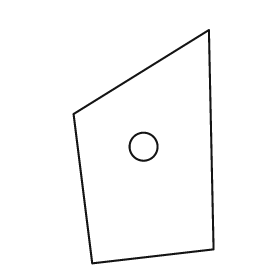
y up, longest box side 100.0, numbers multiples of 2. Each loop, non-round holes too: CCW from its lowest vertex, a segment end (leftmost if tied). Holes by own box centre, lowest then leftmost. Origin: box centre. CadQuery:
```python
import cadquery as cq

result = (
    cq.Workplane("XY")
    .moveTo(-22.0, -50.0)
    .lineTo(30.0, -44.0)
    .lineTo(28.0, 50.0)
    .lineTo(-30.0, 14.0)
    .close()
    .moveTo(0.0, 0.0)
    .circle(6.0)
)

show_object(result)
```